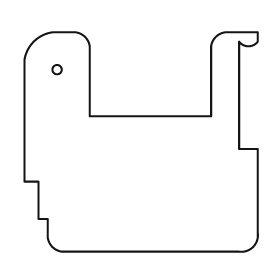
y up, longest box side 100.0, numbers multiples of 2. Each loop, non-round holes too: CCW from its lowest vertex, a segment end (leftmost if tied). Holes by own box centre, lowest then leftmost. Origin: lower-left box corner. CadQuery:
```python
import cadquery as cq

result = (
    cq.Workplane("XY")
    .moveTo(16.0, 0.0)
    .lineTo(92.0, 0.0)
    .threePointArc((98.0, 2.0), (100.0, 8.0))
    .lineTo(100.0, 44.0)
    .lineTo(92.0, 44.0)
    .lineTo(92.0, 90.0)
    .threePointArc((96.0, 88.0), (100.0, 90.0))
    .lineTo(100.0, 94.0)
    .lineTo(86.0, 94.0)
    .threePointArc((82.0, 92.0), (80.0, 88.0))
    .lineTo(80.0, 58.0)
    .lineTo(28.0, 58.0)
    .lineTo(28.0, 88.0)
    .threePointArc((26.0, 92.0), (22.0, 94.0))
    .lineTo(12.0, 94.0)
    .threePointArc((4.0, 90.0), (0.0, 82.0))
    .lineTo(0.0, 30.0)
    .lineTo(6.0, 30.0)
    .lineTo(6.0, 14.0)
    .lineTo(10.0, 14.0)
    .lineTo(10.0, 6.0)
    .threePointArc((12.0, 2.0), (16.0, 0.0))
    .close()
    .moveTo(14.0, 78.0)
    .circle(2.0)
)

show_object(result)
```